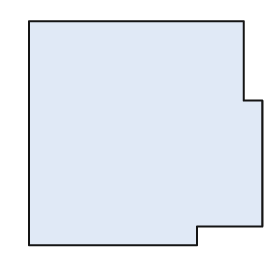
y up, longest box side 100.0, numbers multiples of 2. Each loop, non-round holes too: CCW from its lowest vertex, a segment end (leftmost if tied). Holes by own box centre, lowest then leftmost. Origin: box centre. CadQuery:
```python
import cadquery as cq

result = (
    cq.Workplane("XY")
    .moveTo(-50.0, -48.0)
    .lineTo(22.0, -48.0)
    .lineTo(22.0, -40.0)
    .lineTo(50.0, -40.0)
    .lineTo(50.0, 14.0)
    .lineTo(42.0, 14.0)
    .lineTo(42.0, 48.0)
    .lineTo(-50.0, 48.0)
    .close()
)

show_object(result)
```